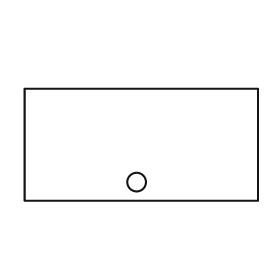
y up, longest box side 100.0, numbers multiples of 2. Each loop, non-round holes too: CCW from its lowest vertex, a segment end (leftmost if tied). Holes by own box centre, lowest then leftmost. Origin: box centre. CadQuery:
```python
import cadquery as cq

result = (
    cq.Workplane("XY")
    .moveTo(-50.0, -24.0)
    .lineTo(50.0, -24.0)
    .lineTo(50.0, 24.0)
    .lineTo(-50.0, 24.0)
    .close()
    .moveTo(-2.0, -16.0)
    .circle(4.0)
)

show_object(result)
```